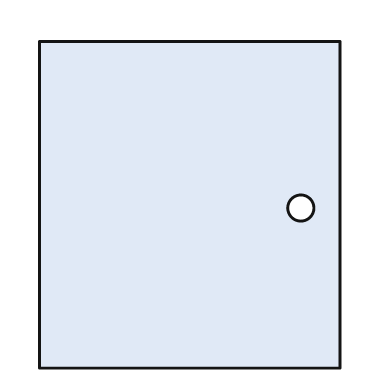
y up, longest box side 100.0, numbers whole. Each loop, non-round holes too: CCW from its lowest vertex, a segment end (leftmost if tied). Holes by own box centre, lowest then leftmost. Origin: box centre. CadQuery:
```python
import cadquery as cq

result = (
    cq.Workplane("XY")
    .moveTo(-46.0, -50.0)
    .lineTo(46.0, -50.0)
    .lineTo(46.0, 50.0)
    .lineTo(-46.0, 50.0)
    .close()
    .moveTo(34.0, -1.0)
    .circle(4.0)
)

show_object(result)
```